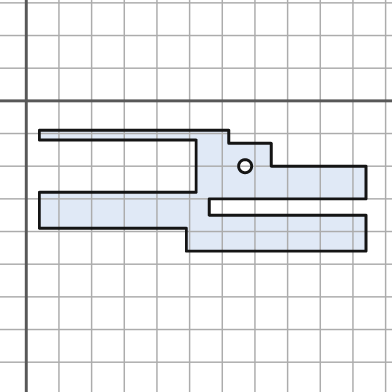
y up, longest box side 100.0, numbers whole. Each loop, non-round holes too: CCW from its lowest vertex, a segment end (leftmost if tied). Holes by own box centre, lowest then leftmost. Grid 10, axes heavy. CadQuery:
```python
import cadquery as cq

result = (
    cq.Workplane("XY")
    .moveTo(49.0, -46.0)
    .lineTo(104.0, -46.0)
    .lineTo(104.0, -35.0)
    .lineTo(56.0, -35.0)
    .lineTo(56.0, -30.0)
    .lineTo(104.0, -30.0)
    .lineTo(104.0, -20.0)
    .lineTo(75.0, -20.0)
    .lineTo(75.0, -13.0)
    .lineTo(62.0, -13.0)
    .lineTo(62.0, -9.0)
    .lineTo(4.0, -9.0)
    .lineTo(4.0, -12.0)
    .lineTo(52.0, -12.0)
    .lineTo(52.0, -28.0)
    .lineTo(4.0, -28.0)
    .lineTo(4.0, -39.0)
    .lineTo(49.0, -39.0)
    .close()
    .moveTo(67.0, -20.0)
    .circle(2.0)
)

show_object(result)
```